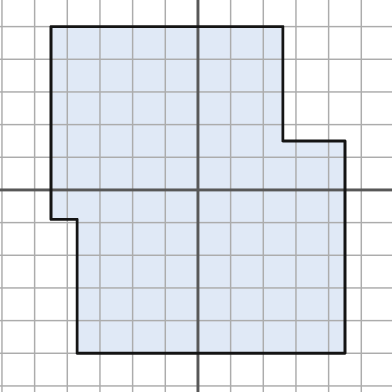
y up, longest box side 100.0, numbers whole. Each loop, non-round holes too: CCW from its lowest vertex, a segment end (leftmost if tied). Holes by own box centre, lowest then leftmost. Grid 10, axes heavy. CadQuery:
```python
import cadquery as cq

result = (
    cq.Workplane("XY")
    .moveTo(-37.0, -50.0)
    .lineTo(45.0, -50.0)
    .lineTo(45.0, 15.0)
    .lineTo(26.0, 15.0)
    .lineTo(26.0, 50.0)
    .lineTo(-45.0, 50.0)
    .lineTo(-45.0, -9.0)
    .lineTo(-37.0, -9.0)
    .close()
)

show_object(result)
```